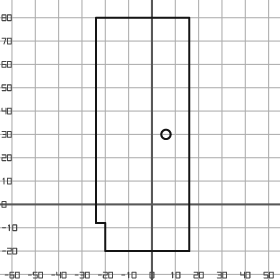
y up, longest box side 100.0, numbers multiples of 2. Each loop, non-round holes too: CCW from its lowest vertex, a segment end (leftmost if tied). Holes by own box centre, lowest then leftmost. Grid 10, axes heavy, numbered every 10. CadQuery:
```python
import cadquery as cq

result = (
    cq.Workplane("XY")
    .moveTo(-20.0, -20.0)
    .lineTo(16.0, -20.0)
    .lineTo(16.0, 80.0)
    .lineTo(-24.0, 80.0)
    .lineTo(-24.0, -8.0)
    .lineTo(-20.0, -8.0)
    .close()
    .moveTo(6.0, 30.0)
    .circle(2.0)
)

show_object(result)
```